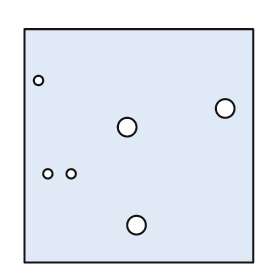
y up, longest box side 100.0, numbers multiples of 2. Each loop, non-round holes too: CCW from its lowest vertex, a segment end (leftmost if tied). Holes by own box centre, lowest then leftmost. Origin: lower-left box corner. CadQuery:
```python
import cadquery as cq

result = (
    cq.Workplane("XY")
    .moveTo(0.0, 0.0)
    .lineTo(98.0, 0.0)
    .lineTo(98.0, 100.0)
    .lineTo(0.0, 100.0)
    .close()
    .moveTo(48.0, 16.0)
    .circle(4.0)
    .moveTo(10.0, 38.0)
    .circle(2.0)
    .moveTo(20.0, 38.0)
    .circle(2.0)
    .moveTo(44.0, 58.0)
    .circle(4.0)
    .moveTo(86.0, 66.0)
    .circle(4.0)
    .moveTo(6.0, 78.0)
    .circle(2.0)
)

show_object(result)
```